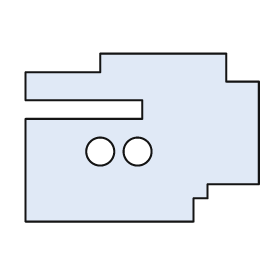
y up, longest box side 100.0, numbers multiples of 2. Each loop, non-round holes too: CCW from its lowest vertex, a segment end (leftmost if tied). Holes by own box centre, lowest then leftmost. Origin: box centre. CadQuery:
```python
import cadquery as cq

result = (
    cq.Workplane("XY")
    .moveTo(-50.0, -36.0)
    .lineTo(22.0, -36.0)
    .lineTo(22.0, -26.0)
    .lineTo(28.0, -26.0)
    .lineTo(28.0, -20.0)
    .lineTo(50.0, -20.0)
    .lineTo(50.0, 24.0)
    .lineTo(36.0, 24.0)
    .lineTo(36.0, 36.0)
    .lineTo(-18.0, 36.0)
    .lineTo(-18.0, 28.0)
    .lineTo(-50.0, 28.0)
    .lineTo(-50.0, 16.0)
    .lineTo(0.0, 16.0)
    .lineTo(0.0, 8.0)
    .lineTo(-50.0, 8.0)
    .close()
    .moveTo(-18.0, -6.0)
    .circle(6.0)
    .moveTo(-2.0, -6.0)
    .circle(6.0)
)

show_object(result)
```